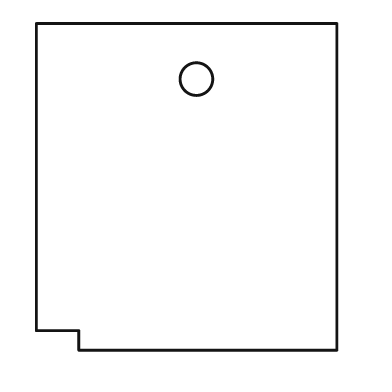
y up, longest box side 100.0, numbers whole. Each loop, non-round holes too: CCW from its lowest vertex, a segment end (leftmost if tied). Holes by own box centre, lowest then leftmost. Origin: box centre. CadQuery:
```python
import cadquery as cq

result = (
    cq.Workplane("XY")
    .moveTo(-33.0, -50.0)
    .lineTo(46.0, -50.0)
    .lineTo(46.0, 50.0)
    .lineTo(-46.0, 50.0)
    .lineTo(-46.0, -44.0)
    .lineTo(-33.0, -44.0)
    .close()
    .moveTo(3.0, 33.0)
    .circle(5.0)
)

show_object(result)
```